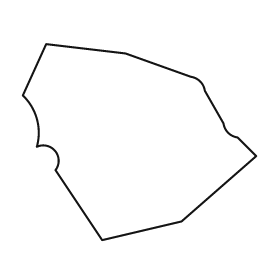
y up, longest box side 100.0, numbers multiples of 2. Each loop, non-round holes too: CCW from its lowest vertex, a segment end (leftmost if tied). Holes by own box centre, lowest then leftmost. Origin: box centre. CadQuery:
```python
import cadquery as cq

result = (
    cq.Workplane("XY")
    .moveTo(-16.0, -42.0)
    .lineTo(18.0, -34.0)
    .lineTo(50.0, -6.0)
    .lineTo(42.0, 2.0)
    .threePointArc((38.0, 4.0), (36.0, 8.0))
    .lineTo(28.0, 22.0)
    .threePointArc((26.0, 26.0), (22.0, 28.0))
    .lineTo(-6.0, 38.0)
    .lineTo(-40.0, 42.0)
    .lineTo(-50.0, 20.0)
    .threePointArc((-44.0, 10.0), (-44.0, -2.0))
    .threePointArc((-36.0, -4.0), (-36.0, -12.0))
    .close()
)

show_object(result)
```